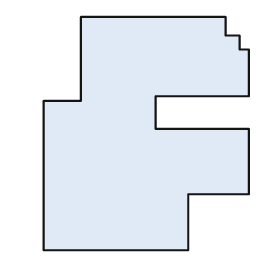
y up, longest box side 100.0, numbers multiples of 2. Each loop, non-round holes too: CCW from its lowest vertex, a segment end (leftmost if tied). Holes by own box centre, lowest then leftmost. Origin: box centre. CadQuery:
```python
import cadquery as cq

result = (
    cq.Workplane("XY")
    .moveTo(-44.0, -50.0)
    .lineTo(18.0, -50.0)
    .lineTo(18.0, -26.0)
    .lineTo(44.0, -26.0)
    .lineTo(44.0, 2.0)
    .lineTo(4.0, 2.0)
    .lineTo(4.0, 16.0)
    .lineTo(44.0, 16.0)
    .lineTo(44.0, 36.0)
    .lineTo(40.0, 36.0)
    .lineTo(40.0, 42.0)
    .lineTo(34.0, 42.0)
    .lineTo(34.0, 50.0)
    .lineTo(-28.0, 50.0)
    .lineTo(-28.0, 14.0)
    .lineTo(-44.0, 14.0)
    .close()
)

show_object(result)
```